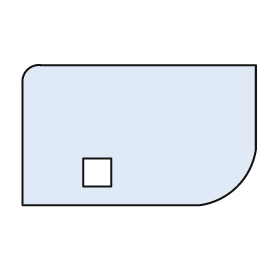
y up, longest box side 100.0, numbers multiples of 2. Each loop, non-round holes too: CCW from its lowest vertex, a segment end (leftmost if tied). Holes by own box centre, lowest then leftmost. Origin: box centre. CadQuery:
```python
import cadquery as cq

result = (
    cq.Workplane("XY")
    .moveTo(-50.0, -30.0)
    .lineTo(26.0, -30.0)
    .threePointArc((42.0, -22.0), (50.0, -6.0))
    .lineTo(50.0, 30.0)
    .lineTo(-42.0, 30.0)
    .threePointArc((-48.0, 28.0), (-50.0, 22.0))
    .close()
    .moveTo(-24.0, -22.0)
    .lineTo(-12.0, -22.0)
    .lineTo(-12.0, -10.0)
    .lineTo(-24.0, -10.0)
    .close()
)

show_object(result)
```